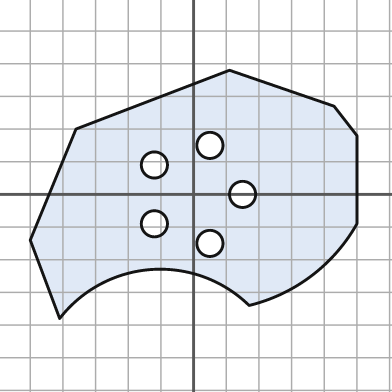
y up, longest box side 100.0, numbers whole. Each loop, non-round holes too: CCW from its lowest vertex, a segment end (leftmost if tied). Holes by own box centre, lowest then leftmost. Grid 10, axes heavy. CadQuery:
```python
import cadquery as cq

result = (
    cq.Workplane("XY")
    .moveTo(-41.0, -38.0)
    .threePointArc((-13.0, -23.0), (17.0, -34.0))
    .threePointArc((36.0, -25.0), (50.0, -9.0))
    .lineTo(50.0, 18.0)
    .lineTo(43.0, 27.0)
    .lineTo(11.0, 38.0)
    .lineTo(-36.0, 20.0)
    .lineTo(-50.0, -14.0)
    .close()
    .moveTo(5.0, -15.0)
    .circle(4.0)
    .moveTo(-12.0, -9.0)
    .circle(4.0)
    .moveTo(15.0, 0.0)
    .circle(4.0)
    .moveTo(-12.0, 9.0)
    .circle(4.0)
    .moveTo(5.0, 15.0)
    .circle(4.0)
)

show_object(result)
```